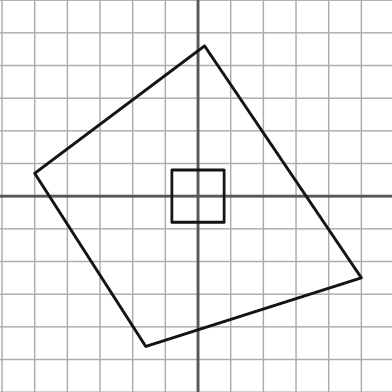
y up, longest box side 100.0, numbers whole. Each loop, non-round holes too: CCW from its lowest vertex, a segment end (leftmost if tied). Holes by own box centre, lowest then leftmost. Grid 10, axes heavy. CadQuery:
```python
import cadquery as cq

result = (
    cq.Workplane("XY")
    .moveTo(-16.0, -46.0)
    .lineTo(50.0, -25.0)
    .lineTo(2.0, 46.0)
    .lineTo(-50.0, 7.0)
    .close()
    .moveTo(-8.0, -8.0)
    .lineTo(8.0, -8.0)
    .lineTo(8.0, 8.0)
    .lineTo(-8.0, 8.0)
    .close()
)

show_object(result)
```